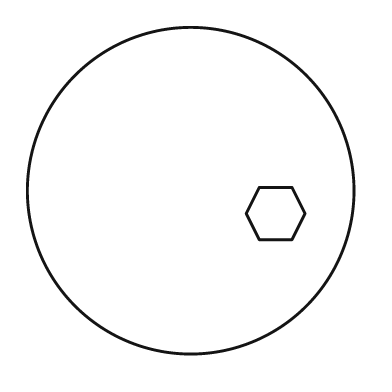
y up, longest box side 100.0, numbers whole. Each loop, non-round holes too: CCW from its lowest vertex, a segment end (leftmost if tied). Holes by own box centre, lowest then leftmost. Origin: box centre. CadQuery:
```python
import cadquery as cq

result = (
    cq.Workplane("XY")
    .moveTo(0.0, 0.0)
    .circle(50.0)
    .moveTo(21.0, -15.0)
    .lineTo(31.0, -15.0)
    .lineTo(35.0, -7.0)
    .lineTo(31.0, 1.0)
    .lineTo(21.0, 1.0)
    .lineTo(17.0, -7.0)
    .close()
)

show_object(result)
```